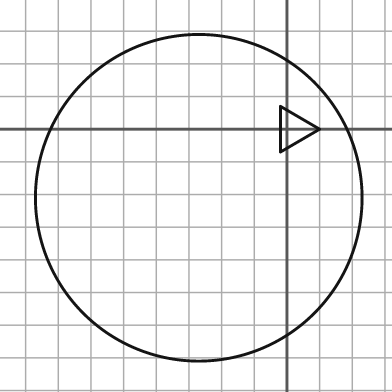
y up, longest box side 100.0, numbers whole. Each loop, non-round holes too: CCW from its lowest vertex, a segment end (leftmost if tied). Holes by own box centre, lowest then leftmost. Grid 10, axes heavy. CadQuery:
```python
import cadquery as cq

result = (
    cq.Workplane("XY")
    .moveTo(-27.0, -21.0)
    .circle(50.0)
    .moveTo(-2.0, -7.0)
    .lineTo(10.0, 0.0)
    .lineTo(-2.0, 7.0)
    .close()
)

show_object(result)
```